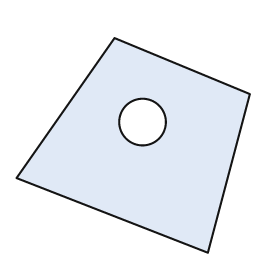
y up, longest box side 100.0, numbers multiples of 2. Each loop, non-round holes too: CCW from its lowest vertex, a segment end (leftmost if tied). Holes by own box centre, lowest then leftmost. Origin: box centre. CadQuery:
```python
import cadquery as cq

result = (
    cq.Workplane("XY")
    .moveTo(32.0, -46.0)
    .lineTo(50.0, 22.0)
    .lineTo(-8.0, 46.0)
    .lineTo(-50.0, -14.0)
    .close()
    .moveTo(4.0, 10.0)
    .circle(10.0)
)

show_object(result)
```